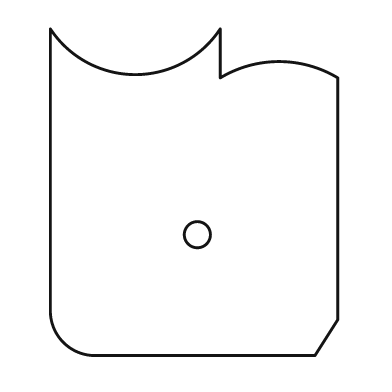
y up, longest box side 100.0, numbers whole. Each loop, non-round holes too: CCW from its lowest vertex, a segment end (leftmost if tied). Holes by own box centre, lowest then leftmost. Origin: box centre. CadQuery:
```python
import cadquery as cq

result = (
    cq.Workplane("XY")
    .moveTo(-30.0, -50.0)
    .lineTo(37.0, -50.0)
    .lineTo(44.0, -39.0)
    .lineTo(44.0, 35.0)
    .threePointArc((26.0, 40.0), (8.0, 35.0))
    .lineTo(8.0, 50.0)
    .threePointArc((-18.0, 36.0), (-44.0, 50.0))
    .lineTo(-44.0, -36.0)
    .threePointArc((-40.0, -46.0), (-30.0, -50.0))
    .close()
    .moveTo(1.0, -13.0)
    .circle(4.0)
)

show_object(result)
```